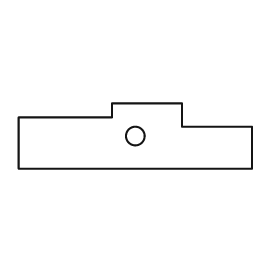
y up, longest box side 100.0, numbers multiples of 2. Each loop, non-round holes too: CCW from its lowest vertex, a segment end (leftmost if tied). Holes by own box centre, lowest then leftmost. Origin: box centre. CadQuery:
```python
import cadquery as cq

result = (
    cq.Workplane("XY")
    .moveTo(-50.0, -14.0)
    .lineTo(50.0, -14.0)
    .lineTo(50.0, 4.0)
    .lineTo(20.0, 4.0)
    .lineTo(20.0, 14.0)
    .lineTo(-10.0, 14.0)
    .lineTo(-10.0, 8.0)
    .lineTo(-50.0, 8.0)
    .close()
    .moveTo(0.0, 0.0)
    .circle(4.0)
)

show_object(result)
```